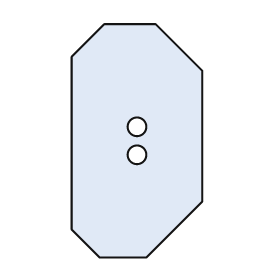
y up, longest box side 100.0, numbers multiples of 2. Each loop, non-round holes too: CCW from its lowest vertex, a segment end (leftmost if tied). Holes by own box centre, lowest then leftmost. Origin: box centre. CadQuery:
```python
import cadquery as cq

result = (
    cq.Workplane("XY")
    .moveTo(-16.0, -50.0)
    .lineTo(4.0, -50.0)
    .lineTo(28.0, -26.0)
    .lineTo(28.0, 30.0)
    .lineTo(8.0, 50.0)
    .lineTo(-14.0, 50.0)
    .lineTo(-28.0, 36.0)
    .lineTo(-28.0, -38.0)
    .close()
    .moveTo(0.0, -6.0)
    .circle(4.0)
    .moveTo(0.0, 6.0)
    .circle(4.0)
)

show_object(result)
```